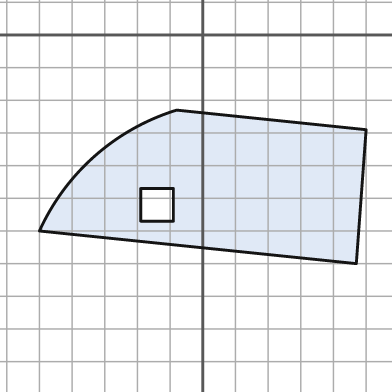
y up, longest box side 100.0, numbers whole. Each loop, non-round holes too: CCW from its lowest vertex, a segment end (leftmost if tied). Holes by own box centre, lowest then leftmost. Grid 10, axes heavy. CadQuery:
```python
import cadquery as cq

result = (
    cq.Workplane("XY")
    .moveTo(47.0, -70.0)
    .lineTo(50.0, -29.0)
    .lineTo(-8.0, -23.0)
    .threePointArc((-33.0, -37.0), (-50.0, -60.0))
    .close()
    .moveTo(-19.0, -57.0)
    .lineTo(-9.0, -57.0)
    .lineTo(-9.0, -47.0)
    .lineTo(-19.0, -47.0)
    .close()
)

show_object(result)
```